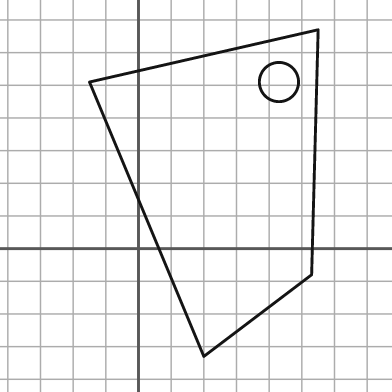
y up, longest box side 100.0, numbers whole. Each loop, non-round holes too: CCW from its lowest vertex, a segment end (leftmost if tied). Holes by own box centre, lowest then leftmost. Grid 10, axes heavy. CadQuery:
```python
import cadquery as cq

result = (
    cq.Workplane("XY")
    .moveTo(20.0, -33.0)
    .lineTo(53.0, -8.0)
    .lineTo(55.0, 67.0)
    .lineTo(-15.0, 51.0)
    .close()
    .moveTo(43.0, 51.0)
    .circle(6.0)
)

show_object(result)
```